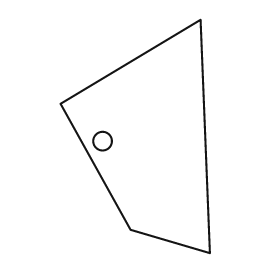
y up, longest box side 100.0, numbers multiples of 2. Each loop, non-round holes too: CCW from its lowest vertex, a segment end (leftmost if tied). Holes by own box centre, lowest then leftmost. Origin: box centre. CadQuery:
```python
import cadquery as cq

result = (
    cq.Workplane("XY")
    .moveTo(32.0, -50.0)
    .lineTo(28.0, 50.0)
    .lineTo(-32.0, 14.0)
    .lineTo(-2.0, -40.0)
    .close()
    .moveTo(-14.0, -2.0)
    .circle(4.0)
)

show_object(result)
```